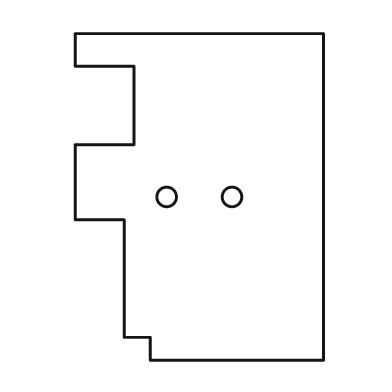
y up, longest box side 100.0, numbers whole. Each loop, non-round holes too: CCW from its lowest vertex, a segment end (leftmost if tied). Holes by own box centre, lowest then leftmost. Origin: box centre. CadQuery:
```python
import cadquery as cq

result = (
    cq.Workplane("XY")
    .moveTo(-15.0, -50.0)
    .lineTo(38.0, -50.0)
    .lineTo(38.0, 50.0)
    .lineTo(-38.0, 50.0)
    .lineTo(-38.0, 40.0)
    .lineTo(-20.0, 40.0)
    .lineTo(-20.0, 16.0)
    .lineTo(-38.0, 16.0)
    .lineTo(-38.0, -7.0)
    .lineTo(-23.0, -7.0)
    .lineTo(-23.0, -43.0)
    .lineTo(-15.0, -43.0)
    .close()
    .moveTo(-10.0, 0.0)
    .circle(3.0)
    .moveTo(10.0, 0.0)
    .circle(3.0)
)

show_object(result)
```